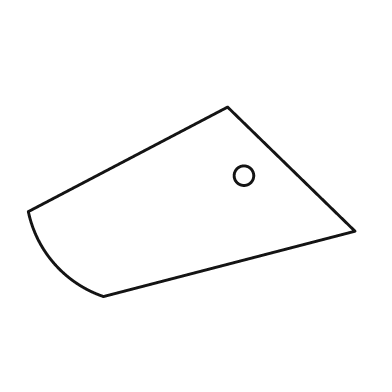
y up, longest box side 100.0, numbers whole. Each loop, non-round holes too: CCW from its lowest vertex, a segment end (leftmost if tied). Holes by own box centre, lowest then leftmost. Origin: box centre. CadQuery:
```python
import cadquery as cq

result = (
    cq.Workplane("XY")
    .moveTo(-27.0, -29.0)
    .lineTo(50.0, -9.0)
    .lineTo(11.0, 29.0)
    .lineTo(-50.0, -3.0)
    .threePointArc((-42.0, -19.0), (-27.0, -29.0))
    .close()
    .moveTo(16.0, 8.0)
    .circle(3.0)
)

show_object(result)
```